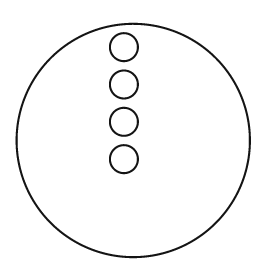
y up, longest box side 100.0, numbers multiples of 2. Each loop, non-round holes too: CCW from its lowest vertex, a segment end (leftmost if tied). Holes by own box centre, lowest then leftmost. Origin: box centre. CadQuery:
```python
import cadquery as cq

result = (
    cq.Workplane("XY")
    .moveTo(0.0, 0.0)
    .circle(50.0)
    .moveTo(-4.0, -8.0)
    .circle(6.0)
    .moveTo(-4.0, 8.0)
    .circle(6.0)
    .moveTo(-4.0, 24.0)
    .circle(6.0)
    .moveTo(-4.0, 40.0)
    .circle(6.0)
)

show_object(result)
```